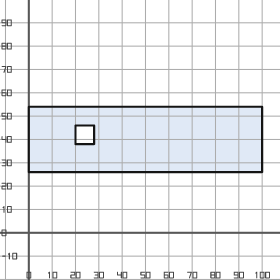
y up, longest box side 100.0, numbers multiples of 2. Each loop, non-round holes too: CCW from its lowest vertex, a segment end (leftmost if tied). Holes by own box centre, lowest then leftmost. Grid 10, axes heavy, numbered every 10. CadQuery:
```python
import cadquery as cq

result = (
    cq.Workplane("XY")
    .moveTo(0.0, 26.0)
    .lineTo(100.0, 26.0)
    .lineTo(100.0, 54.0)
    .lineTo(0.0, 54.0)
    .close()
    .moveTo(20.0, 38.0)
    .lineTo(28.0, 38.0)
    .lineTo(28.0, 46.0)
    .lineTo(20.0, 46.0)
    .close()
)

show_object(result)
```